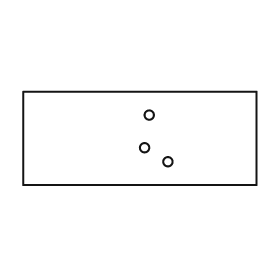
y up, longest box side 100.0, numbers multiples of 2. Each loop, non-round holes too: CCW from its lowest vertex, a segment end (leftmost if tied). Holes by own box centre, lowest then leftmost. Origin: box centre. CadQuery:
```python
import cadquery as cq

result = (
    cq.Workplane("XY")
    .moveTo(-50.0, -20.0)
    .lineTo(50.0, -20.0)
    .lineTo(50.0, 20.0)
    .lineTo(-50.0, 20.0)
    .close()
    .moveTo(12.0, -10.0)
    .circle(2.0)
    .moveTo(2.0, -4.0)
    .circle(2.0)
    .moveTo(4.0, 10.0)
    .circle(2.0)
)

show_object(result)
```